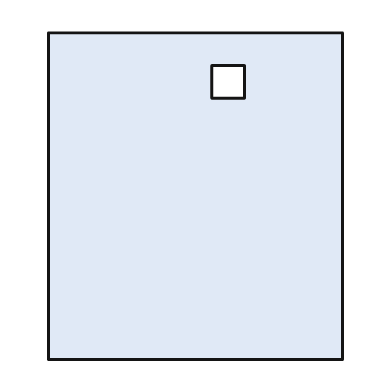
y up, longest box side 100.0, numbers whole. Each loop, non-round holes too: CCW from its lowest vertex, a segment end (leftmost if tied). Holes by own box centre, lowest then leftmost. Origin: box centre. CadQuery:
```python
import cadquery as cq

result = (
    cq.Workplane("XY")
    .moveTo(-45.0, -50.0)
    .lineTo(45.0, -50.0)
    .lineTo(45.0, 50.0)
    .lineTo(-45.0, 50.0)
    .close()
    .moveTo(5.0, 30.0)
    .lineTo(15.0, 30.0)
    .lineTo(15.0, 40.0)
    .lineTo(5.0, 40.0)
    .close()
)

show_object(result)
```